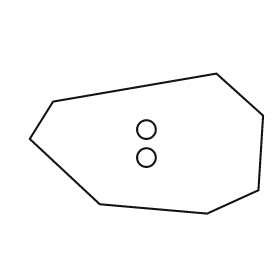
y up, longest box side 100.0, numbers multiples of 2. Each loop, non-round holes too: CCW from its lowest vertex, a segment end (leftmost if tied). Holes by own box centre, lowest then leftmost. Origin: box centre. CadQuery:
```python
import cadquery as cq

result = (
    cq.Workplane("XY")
    .moveTo(26.0, -30.0)
    .lineTo(48.0, -20.0)
    .lineTo(50.0, 12.0)
    .lineTo(30.0, 30.0)
    .lineTo(-40.0, 18.0)
    .lineTo(-50.0, 2.0)
    .lineTo(-20.0, -26.0)
    .close()
    .moveTo(0.0, -6.0)
    .circle(4.0)
    .moveTo(0.0, 6.0)
    .circle(4.0)
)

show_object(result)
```